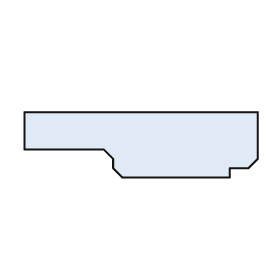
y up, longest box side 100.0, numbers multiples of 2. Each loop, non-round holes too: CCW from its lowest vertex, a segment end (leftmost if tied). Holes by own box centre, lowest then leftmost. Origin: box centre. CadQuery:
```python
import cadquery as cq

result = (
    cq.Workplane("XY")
    .moveTo(-8.0, -14.0)
    .lineTo(38.0, -14.0)
    .lineTo(38.0, -10.0)
    .lineTo(46.0, -10.0)
    .lineTo(50.0, -6.0)
    .lineTo(50.0, 14.0)
    .lineTo(-50.0, 14.0)
    .lineTo(-50.0, -2.0)
    .lineTo(-16.0, -2.0)
    .lineTo(-12.0, -6.0)
    .lineTo(-12.0, -10.0)
    .close()
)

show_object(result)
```